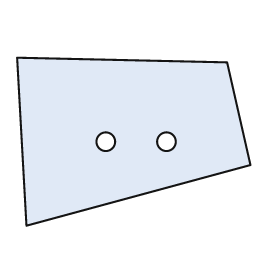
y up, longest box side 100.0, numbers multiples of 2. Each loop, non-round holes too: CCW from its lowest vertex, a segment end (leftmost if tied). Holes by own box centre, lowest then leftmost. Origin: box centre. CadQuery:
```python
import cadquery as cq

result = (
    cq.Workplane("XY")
    .moveTo(-46.0, -36.0)
    .lineTo(50.0, -10.0)
    .lineTo(40.0, 34.0)
    .lineTo(-50.0, 36.0)
    .close()
    .moveTo(-12.0, 0.0)
    .circle(4.0)
    .moveTo(14.0, 0.0)
    .circle(4.0)
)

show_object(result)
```